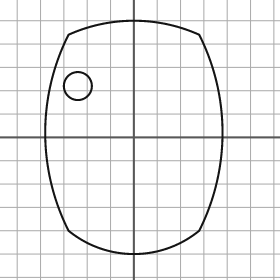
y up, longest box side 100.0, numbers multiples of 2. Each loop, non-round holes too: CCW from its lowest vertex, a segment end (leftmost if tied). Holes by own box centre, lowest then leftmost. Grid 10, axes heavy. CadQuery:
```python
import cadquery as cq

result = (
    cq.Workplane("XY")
    .moveTo(-28.0, -40.0)
    .threePointArc((0.0, -50.0), (28.0, -40.0))
    .threePointArc((38.0, 2.0), (28.0, 44.0))
    .threePointArc((0.0, 50.0), (-28.0, 44.0))
    .threePointArc((-38.0, 2.0), (-28.0, -40.0))
    .close()
    .moveTo(-24.0, 22.0)
    .circle(6.0)
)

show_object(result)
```